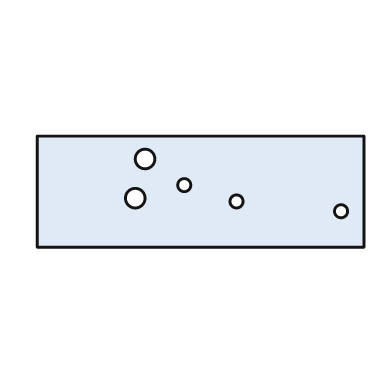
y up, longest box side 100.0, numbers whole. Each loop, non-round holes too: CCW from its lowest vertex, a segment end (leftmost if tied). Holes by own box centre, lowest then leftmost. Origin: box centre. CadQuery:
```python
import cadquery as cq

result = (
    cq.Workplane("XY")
    .moveTo(-50.0, -17.0)
    .lineTo(50.0, -17.0)
    .lineTo(50.0, 17.0)
    .lineTo(-50.0, 17.0)
    .close()
    .moveTo(43.0, -6.0)
    .circle(2.0)
    .moveTo(11.0, -3.0)
    .circle(2.0)
    .moveTo(-20.0, -2.0)
    .circle(3.0)
    .moveTo(-5.0, 2.0)
    .circle(2.0)
    .moveTo(-17.0, 10.0)
    .circle(3.0)
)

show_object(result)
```